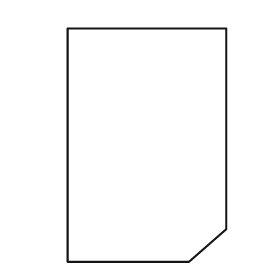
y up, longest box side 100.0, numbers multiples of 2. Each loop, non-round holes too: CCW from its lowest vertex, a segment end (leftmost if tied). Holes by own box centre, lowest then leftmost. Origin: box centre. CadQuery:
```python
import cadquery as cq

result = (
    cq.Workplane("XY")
    .moveTo(-34.0, -50.0)
    .lineTo(18.0, -50.0)
    .lineTo(34.0, -36.0)
    .lineTo(34.0, 50.0)
    .lineTo(-34.0, 50.0)
    .close()
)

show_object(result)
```